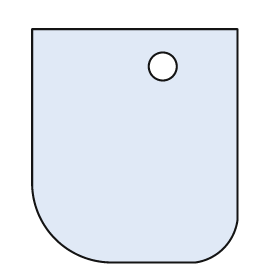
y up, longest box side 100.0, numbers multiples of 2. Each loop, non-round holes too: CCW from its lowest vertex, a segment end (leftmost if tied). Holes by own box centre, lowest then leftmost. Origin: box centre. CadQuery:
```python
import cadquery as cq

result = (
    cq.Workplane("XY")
    .moveTo(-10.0, -50.0)
    .lineTo(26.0, -50.0)
    .threePointArc((38.0, -44.0), (44.0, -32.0))
    .lineTo(44.0, 50.0)
    .lineTo(-44.0, 50.0)
    .lineTo(-44.0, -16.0)
    .threePointArc((-34.0, -40.0), (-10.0, -50.0))
    .close()
    .moveTo(12.0, 34.0)
    .circle(6.0)
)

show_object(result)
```